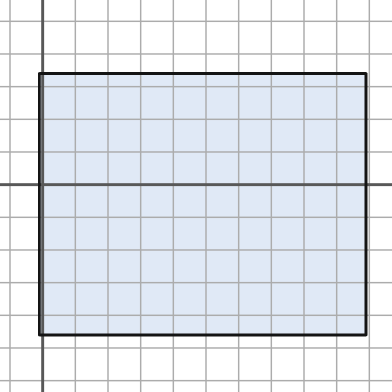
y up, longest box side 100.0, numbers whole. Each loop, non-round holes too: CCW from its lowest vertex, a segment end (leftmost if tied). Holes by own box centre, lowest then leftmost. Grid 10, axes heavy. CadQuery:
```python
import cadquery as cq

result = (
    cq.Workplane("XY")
    .moveTo(-1.0, -46.0)
    .lineTo(99.0, -46.0)
    .lineTo(99.0, 34.0)
    .lineTo(-1.0, 34.0)
    .close()
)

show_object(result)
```